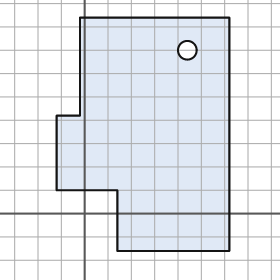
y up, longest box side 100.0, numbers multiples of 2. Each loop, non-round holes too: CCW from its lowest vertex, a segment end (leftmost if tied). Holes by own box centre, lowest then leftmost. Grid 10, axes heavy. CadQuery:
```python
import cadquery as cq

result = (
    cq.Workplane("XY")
    .moveTo(14.0, -16.0)
    .lineTo(62.0, -16.0)
    .lineTo(62.0, 84.0)
    .lineTo(-2.0, 84.0)
    .lineTo(-2.0, 42.0)
    .lineTo(-12.0, 42.0)
    .lineTo(-12.0, 10.0)
    .lineTo(14.0, 10.0)
    .close()
    .moveTo(44.0, 70.0)
    .circle(4.0)
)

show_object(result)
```